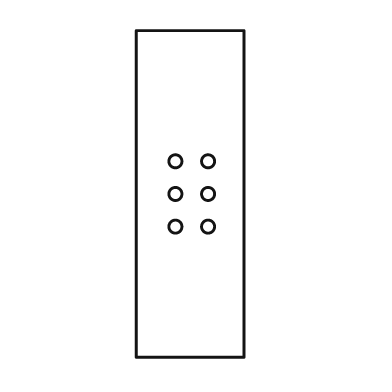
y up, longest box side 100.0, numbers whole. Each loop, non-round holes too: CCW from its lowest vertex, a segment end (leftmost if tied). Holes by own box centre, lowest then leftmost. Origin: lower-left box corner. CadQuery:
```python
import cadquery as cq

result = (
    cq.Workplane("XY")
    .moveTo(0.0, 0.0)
    .lineTo(33.0, 0.0)
    .lineTo(33.0, 100.0)
    .lineTo(0.0, 100.0)
    .close()
    .moveTo(12.0, 40.0)
    .circle(2.0)
    .moveTo(22.0, 40.0)
    .circle(2.0)
    .moveTo(12.0, 50.0)
    .circle(2.0)
    .moveTo(22.0, 50.0)
    .circle(2.0)
    .moveTo(12.0, 60.0)
    .circle(2.0)
    .moveTo(22.0, 60.0)
    .circle(2.0)
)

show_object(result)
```